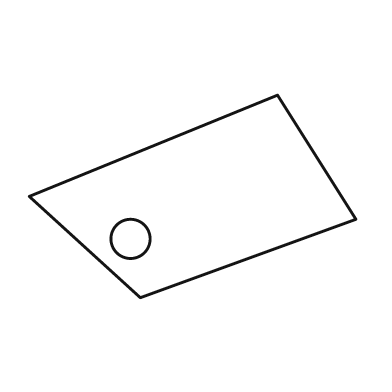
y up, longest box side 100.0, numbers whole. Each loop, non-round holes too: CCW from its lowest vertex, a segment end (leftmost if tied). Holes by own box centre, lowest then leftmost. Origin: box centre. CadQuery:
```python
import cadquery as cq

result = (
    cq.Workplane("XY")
    .moveTo(-16.0, -31.0)
    .lineTo(50.0, -7.0)
    .lineTo(26.0, 31.0)
    .lineTo(-50.0, 0.0)
    .close()
    .moveTo(-19.0, -13.0)
    .circle(6.0)
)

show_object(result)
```